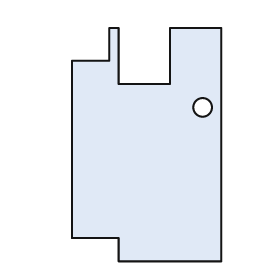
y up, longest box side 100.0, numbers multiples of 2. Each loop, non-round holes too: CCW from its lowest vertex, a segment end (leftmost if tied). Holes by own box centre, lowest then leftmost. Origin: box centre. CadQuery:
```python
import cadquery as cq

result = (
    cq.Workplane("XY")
    .moveTo(-12.0, -50.0)
    .lineTo(32.0, -50.0)
    .lineTo(32.0, 50.0)
    .lineTo(10.0, 50.0)
    .lineTo(10.0, 26.0)
    .lineTo(-12.0, 26.0)
    .lineTo(-12.0, 50.0)
    .lineTo(-16.0, 50.0)
    .lineTo(-16.0, 36.0)
    .lineTo(-32.0, 36.0)
    .lineTo(-32.0, -40.0)
    .lineTo(-12.0, -40.0)
    .close()
    .moveTo(24.0, 16.0)
    .circle(4.0)
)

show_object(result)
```